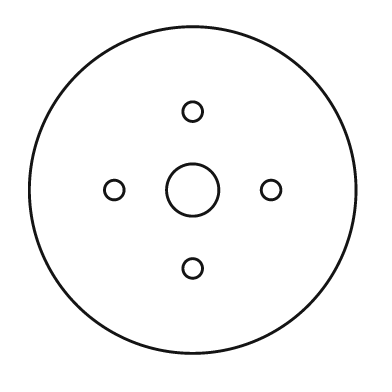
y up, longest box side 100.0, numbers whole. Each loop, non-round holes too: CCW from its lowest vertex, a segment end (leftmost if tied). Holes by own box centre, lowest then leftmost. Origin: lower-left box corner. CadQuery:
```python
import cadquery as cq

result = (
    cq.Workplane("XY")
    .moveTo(50.0, 50.0)
    .circle(50.0)
    .moveTo(50.0, 26.0)
    .circle(3.0)
    .moveTo(26.0, 50.0)
    .circle(3.0)
    .moveTo(50.0, 50.0)
    .circle(8.0)
    .moveTo(74.0, 50.0)
    .circle(3.0)
    .moveTo(50.0, 74.0)
    .circle(3.0)
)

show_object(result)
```